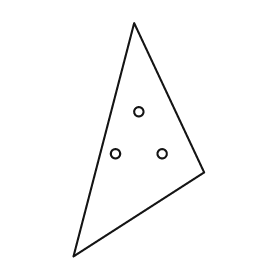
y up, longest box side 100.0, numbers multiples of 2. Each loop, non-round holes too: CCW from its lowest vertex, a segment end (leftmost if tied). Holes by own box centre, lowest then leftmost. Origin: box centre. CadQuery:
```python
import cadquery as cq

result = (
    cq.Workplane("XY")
    .moveTo(-28.0, -50.0)
    .lineTo(28.0, -14.0)
    .lineTo(-2.0, 50.0)
    .close()
    .moveTo(-10.0, -6.0)
    .circle(2.0)
    .moveTo(10.0, -6.0)
    .circle(2.0)
    .moveTo(0.0, 12.0)
    .circle(2.0)
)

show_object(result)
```